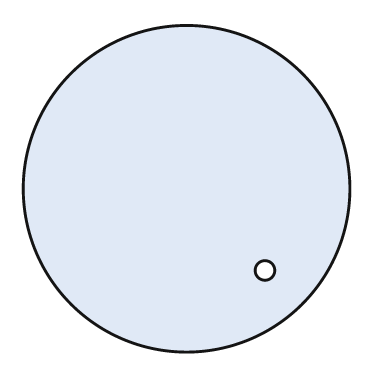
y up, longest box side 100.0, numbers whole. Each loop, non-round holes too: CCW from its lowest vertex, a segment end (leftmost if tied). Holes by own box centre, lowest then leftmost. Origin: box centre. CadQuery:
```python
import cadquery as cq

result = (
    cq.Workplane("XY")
    .moveTo(0.0, 0.0)
    .circle(50.0)
    .moveTo(24.0, -25.0)
    .circle(3.0)
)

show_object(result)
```